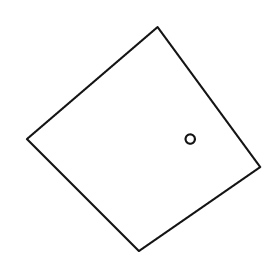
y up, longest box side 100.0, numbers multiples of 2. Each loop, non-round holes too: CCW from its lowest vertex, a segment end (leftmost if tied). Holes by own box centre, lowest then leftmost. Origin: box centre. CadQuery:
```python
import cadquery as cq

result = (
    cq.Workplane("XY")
    .moveTo(-2.0, -48.0)
    .lineTo(50.0, -12.0)
    .lineTo(6.0, 48.0)
    .lineTo(-50.0, 0.0)
    .close()
    .moveTo(20.0, 0.0)
    .circle(2.0)
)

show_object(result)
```